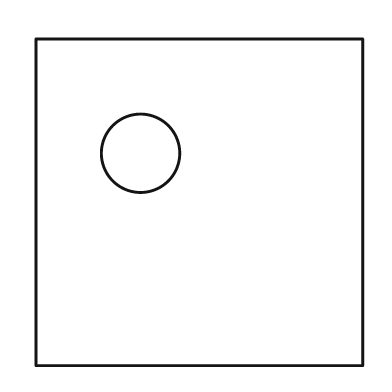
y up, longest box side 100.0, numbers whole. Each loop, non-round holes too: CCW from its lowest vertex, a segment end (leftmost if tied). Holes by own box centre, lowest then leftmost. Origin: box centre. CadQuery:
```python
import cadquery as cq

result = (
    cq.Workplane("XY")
    .moveTo(-50.0, -50.0)
    .lineTo(50.0, -50.0)
    .lineTo(50.0, 50.0)
    .lineTo(-50.0, 50.0)
    .close()
    .moveTo(-18.0, 15.0)
    .circle(12.0)
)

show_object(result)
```